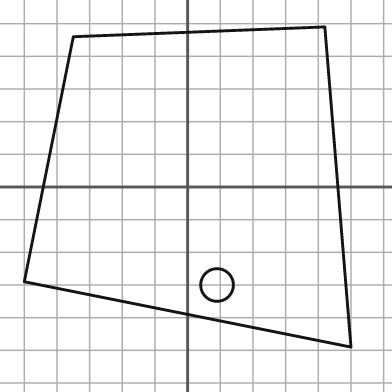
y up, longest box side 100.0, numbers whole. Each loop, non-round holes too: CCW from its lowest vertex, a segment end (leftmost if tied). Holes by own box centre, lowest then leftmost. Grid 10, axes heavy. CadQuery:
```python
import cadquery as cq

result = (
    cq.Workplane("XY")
    .moveTo(50.0, -49.0)
    .lineTo(42.0, 49.0)
    .lineTo(-35.0, 46.0)
    .lineTo(-50.0, -29.0)
    .close()
    .moveTo(9.0, -30.0)
    .circle(5.0)
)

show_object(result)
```